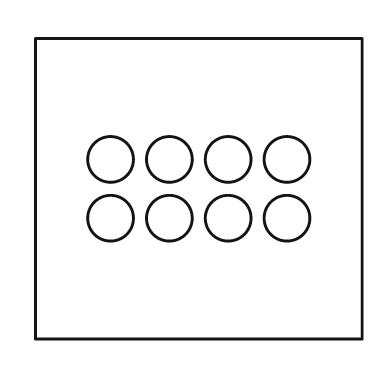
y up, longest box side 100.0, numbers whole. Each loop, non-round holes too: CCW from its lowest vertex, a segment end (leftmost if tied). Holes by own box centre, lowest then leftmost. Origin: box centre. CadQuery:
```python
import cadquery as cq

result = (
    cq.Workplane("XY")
    .moveTo(-50.0, -46.0)
    .lineTo(50.0, -46.0)
    .lineTo(50.0, 46.0)
    .lineTo(-50.0, 46.0)
    .close()
    .moveTo(-27.0, -9.0)
    .circle(7.0)
    .moveTo(-9.0, -9.0)
    .circle(7.0)
    .moveTo(9.0, -9.0)
    .circle(7.0)
    .moveTo(27.0, -9.0)
    .circle(7.0)
    .moveTo(-27.0, 9.0)
    .circle(7.0)
    .moveTo(-9.0, 9.0)
    .circle(7.0)
    .moveTo(9.0, 9.0)
    .circle(7.0)
    .moveTo(27.0, 9.0)
    .circle(7.0)
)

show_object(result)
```